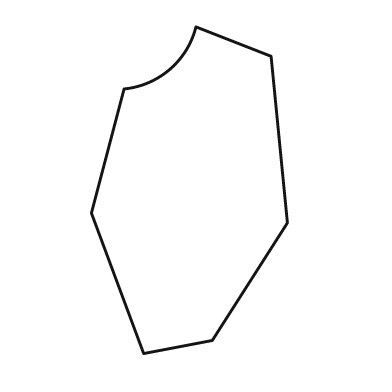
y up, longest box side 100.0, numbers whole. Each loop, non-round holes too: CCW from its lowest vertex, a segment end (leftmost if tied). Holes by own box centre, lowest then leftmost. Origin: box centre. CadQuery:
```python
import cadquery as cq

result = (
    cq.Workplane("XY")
    .moveTo(-14.0, -50.0)
    .lineTo(7.0, -46.0)
    .lineTo(30.0, -10.0)
    .lineTo(25.0, 41.0)
    .lineTo(2.0, 50.0)
    .threePointArc((-6.0, 37.0), (-20.0, 31.0))
    .lineTo(-30.0, -7.0)
    .close()
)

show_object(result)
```